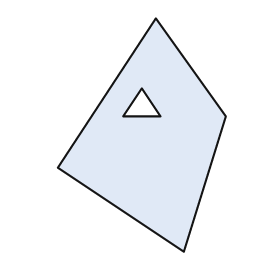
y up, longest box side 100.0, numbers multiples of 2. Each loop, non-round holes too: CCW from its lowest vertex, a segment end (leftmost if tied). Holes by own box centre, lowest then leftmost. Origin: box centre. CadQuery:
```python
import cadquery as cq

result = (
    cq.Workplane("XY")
    .moveTo(18.0, -50.0)
    .lineTo(36.0, 8.0)
    .lineTo(6.0, 50.0)
    .lineTo(-36.0, -14.0)
    .close()
    .moveTo(-8.0, 8.0)
    .lineTo(8.0, 8.0)
    .lineTo(0.0, 20.0)
    .close()
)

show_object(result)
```